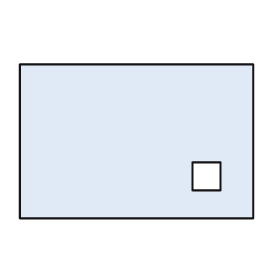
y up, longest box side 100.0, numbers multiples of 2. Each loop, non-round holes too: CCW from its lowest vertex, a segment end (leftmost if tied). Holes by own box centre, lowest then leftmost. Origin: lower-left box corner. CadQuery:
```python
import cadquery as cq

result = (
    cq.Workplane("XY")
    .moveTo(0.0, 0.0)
    .lineTo(100.0, 0.0)
    .lineTo(100.0, 66.0)
    .lineTo(0.0, 66.0)
    .close()
    .moveTo(74.0, 12.0)
    .lineTo(86.0, 12.0)
    .lineTo(86.0, 24.0)
    .lineTo(74.0, 24.0)
    .close()
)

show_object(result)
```